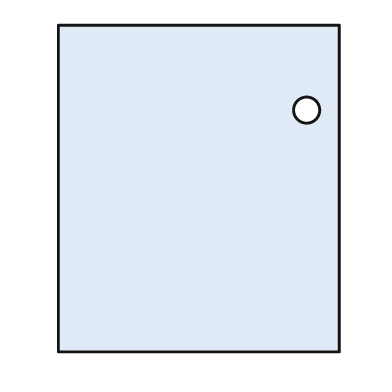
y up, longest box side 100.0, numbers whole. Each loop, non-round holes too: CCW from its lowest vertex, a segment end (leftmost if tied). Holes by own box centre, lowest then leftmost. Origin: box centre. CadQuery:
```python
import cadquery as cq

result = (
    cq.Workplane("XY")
    .moveTo(-43.0, -50.0)
    .lineTo(43.0, -50.0)
    .lineTo(43.0, 50.0)
    .lineTo(-43.0, 50.0)
    .close()
    .moveTo(33.0, 24.0)
    .circle(4.0)
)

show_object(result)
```